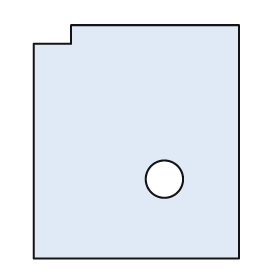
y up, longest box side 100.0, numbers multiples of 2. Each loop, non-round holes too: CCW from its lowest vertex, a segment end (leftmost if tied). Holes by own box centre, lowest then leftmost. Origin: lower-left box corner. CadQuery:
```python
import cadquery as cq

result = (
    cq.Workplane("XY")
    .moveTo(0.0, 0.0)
    .lineTo(88.0, 0.0)
    .lineTo(88.0, 100.0)
    .lineTo(16.0, 100.0)
    .lineTo(16.0, 92.0)
    .lineTo(0.0, 92.0)
    .close()
    .moveTo(56.0, 34.0)
    .circle(8.0)
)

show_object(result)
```